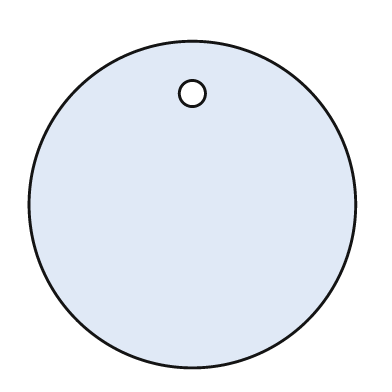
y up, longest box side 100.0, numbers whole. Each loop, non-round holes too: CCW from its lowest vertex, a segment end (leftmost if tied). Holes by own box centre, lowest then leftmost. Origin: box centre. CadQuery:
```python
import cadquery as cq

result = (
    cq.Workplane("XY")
    .moveTo(0.0, 0.0)
    .circle(50.0)
    .moveTo(0.0, 34.0)
    .circle(4.0)
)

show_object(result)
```